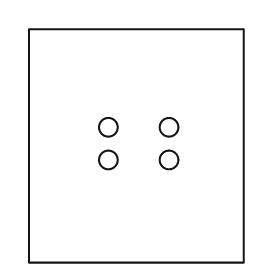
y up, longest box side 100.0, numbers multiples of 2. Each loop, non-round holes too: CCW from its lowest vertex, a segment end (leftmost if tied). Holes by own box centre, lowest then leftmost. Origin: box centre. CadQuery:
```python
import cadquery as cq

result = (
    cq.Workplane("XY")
    .moveTo(-46.0, -50.0)
    .lineTo(46.0, -50.0)
    .lineTo(46.0, 50.0)
    .lineTo(-46.0, 50.0)
    .close()
    .moveTo(-12.0, -6.0)
    .circle(4.0)
    .moveTo(14.0, -6.0)
    .circle(4.0)
    .moveTo(-12.0, 8.0)
    .circle(4.0)
    .moveTo(14.0, 8.0)
    .circle(4.0)
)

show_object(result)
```